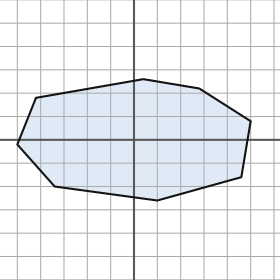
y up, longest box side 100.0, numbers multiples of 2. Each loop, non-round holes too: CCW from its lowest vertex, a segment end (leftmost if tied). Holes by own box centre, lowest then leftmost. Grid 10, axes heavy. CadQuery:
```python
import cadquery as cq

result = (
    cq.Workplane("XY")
    .moveTo(10.0, -26.0)
    .lineTo(46.0, -16.0)
    .lineTo(50.0, 8.0)
    .lineTo(28.0, 22.0)
    .lineTo(4.0, 26.0)
    .lineTo(-42.0, 18.0)
    .lineTo(-50.0, -2.0)
    .lineTo(-34.0, -20.0)
    .close()
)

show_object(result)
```